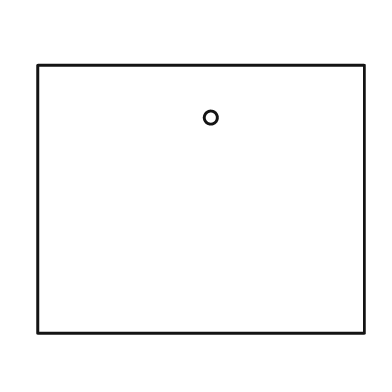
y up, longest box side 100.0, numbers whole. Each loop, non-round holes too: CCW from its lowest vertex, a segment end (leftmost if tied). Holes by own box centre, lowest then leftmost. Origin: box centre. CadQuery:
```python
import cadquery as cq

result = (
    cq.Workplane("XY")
    .moveTo(-50.0, -41.0)
    .lineTo(50.0, -41.0)
    .lineTo(50.0, 41.0)
    .lineTo(-50.0, 41.0)
    .close()
    .moveTo(3.0, 25.0)
    .circle(2.0)
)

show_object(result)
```